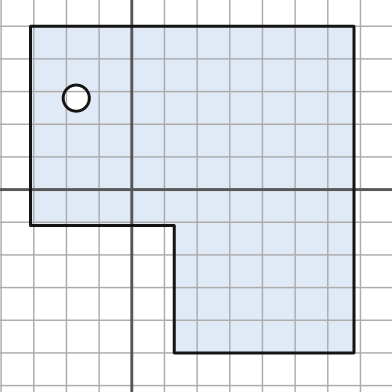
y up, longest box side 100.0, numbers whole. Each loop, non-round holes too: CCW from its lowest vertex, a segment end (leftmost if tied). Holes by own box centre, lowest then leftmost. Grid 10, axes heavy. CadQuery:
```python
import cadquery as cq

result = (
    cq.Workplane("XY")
    .moveTo(13.0, -50.0)
    .lineTo(68.0, -50.0)
    .lineTo(68.0, 50.0)
    .lineTo(-31.0, 50.0)
    .lineTo(-31.0, -11.0)
    .lineTo(13.0, -11.0)
    .close()
    .moveTo(-17.0, 28.0)
    .circle(4.0)
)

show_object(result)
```